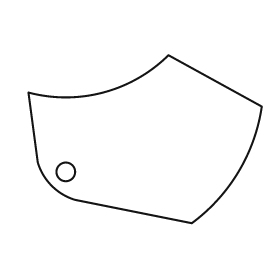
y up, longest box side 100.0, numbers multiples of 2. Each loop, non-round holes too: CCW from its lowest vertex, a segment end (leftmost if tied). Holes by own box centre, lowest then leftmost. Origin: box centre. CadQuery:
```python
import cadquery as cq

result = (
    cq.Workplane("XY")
    .moveTo(20.0, -36.0)
    .threePointArc((40.0, -14.0), (50.0, 14.0))
    .lineTo(10.0, 36.0)
    .threePointArc((-18.0, 20.0), (-50.0, 20.0))
    .lineTo(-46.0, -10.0)
    .threePointArc((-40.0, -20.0), (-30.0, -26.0))
    .close()
    .moveTo(-34.0, -14.0)
    .circle(4.0)
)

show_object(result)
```